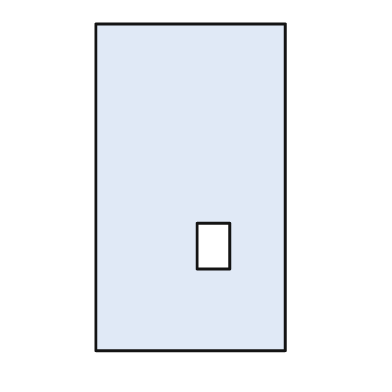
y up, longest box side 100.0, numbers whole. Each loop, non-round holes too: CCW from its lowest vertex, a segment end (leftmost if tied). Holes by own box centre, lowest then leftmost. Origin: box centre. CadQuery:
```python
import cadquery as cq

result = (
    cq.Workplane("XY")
    .moveTo(-29.0, -50.0)
    .lineTo(29.0, -50.0)
    .lineTo(29.0, 50.0)
    .lineTo(-29.0, 50.0)
    .close()
    .moveTo(2.0, -25.0)
    .lineTo(12.0, -25.0)
    .lineTo(12.0, -11.0)
    .lineTo(2.0, -11.0)
    .close()
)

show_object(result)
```